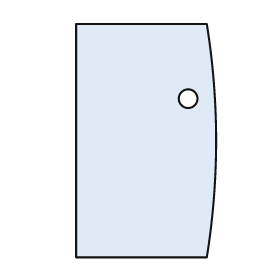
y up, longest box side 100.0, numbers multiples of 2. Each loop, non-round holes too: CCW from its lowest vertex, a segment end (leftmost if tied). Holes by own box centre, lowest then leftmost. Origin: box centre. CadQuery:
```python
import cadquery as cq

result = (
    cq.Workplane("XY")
    .moveTo(-30.0, -50.0)
    .lineTo(26.0, -50.0)
    .threePointArc((30.0, 0.0), (26.0, 50.0))
    .lineTo(-30.0, 50.0)
    .close()
    .moveTo(18.0, 18.0)
    .circle(4.0)
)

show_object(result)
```